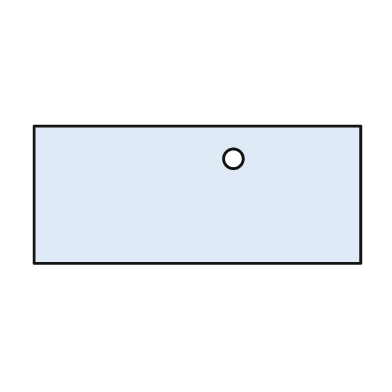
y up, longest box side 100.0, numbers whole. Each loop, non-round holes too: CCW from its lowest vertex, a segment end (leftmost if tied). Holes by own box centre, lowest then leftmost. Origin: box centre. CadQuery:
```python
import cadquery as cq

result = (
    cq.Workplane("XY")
    .moveTo(-50.0, -21.0)
    .lineTo(50.0, -21.0)
    .lineTo(50.0, 21.0)
    .lineTo(-50.0, 21.0)
    .close()
    .moveTo(11.0, 11.0)
    .circle(3.0)
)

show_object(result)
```